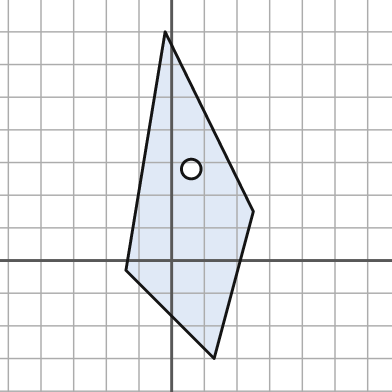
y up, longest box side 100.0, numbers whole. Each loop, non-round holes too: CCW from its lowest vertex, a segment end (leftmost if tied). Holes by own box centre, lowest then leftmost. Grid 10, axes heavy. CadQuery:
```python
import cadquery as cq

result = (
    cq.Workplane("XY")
    .moveTo(13.0, -30.0)
    .lineTo(25.0, 15.0)
    .lineTo(-2.0, 70.0)
    .lineTo(-14.0, -3.0)
    .close()
    .moveTo(6.0, 28.0)
    .circle(3.0)
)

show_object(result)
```